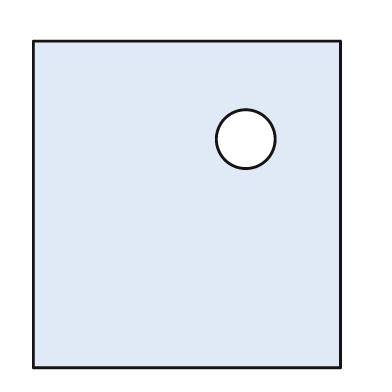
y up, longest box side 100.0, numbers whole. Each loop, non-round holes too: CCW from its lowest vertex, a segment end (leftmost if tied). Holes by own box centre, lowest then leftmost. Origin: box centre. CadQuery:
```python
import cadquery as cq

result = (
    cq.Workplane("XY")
    .moveTo(-47.0, -50.0)
    .lineTo(47.0, -50.0)
    .lineTo(47.0, 50.0)
    .lineTo(-47.0, 50.0)
    .close()
    .moveTo(18.0, 20.0)
    .circle(9.0)
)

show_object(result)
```